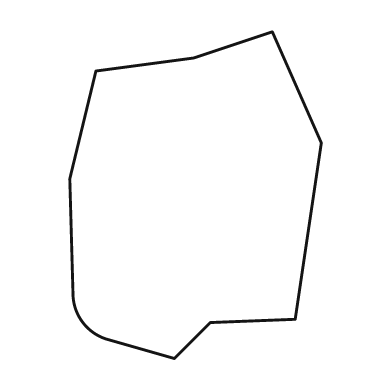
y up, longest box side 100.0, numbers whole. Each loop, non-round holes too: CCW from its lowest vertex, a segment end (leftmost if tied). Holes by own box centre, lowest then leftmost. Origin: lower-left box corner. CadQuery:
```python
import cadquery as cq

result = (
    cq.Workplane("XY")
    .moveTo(32.0, 0.0)
    .lineTo(43.0, 11.0)
    .lineTo(69.0, 12.0)
    .lineTo(77.0, 66.0)
    .lineTo(62.0, 100.0)
    .lineTo(38.0, 92.0)
    .lineTo(8.0, 88.0)
    .lineTo(0.0, 55.0)
    .lineTo(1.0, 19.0)
    .threePointArc((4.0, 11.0), (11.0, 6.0))
    .close()
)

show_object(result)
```